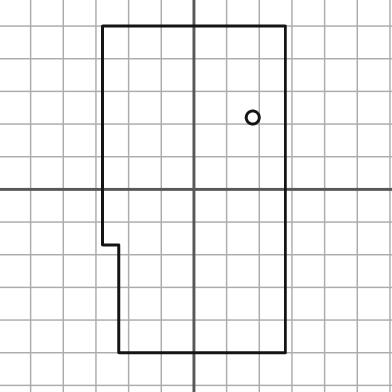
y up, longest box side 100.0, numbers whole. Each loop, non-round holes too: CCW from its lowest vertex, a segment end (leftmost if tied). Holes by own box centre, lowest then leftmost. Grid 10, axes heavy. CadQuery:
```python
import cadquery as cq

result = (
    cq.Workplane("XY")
    .moveTo(-23.0, -50.0)
    .lineTo(28.0, -50.0)
    .lineTo(28.0, 50.0)
    .lineTo(-28.0, 50.0)
    .lineTo(-28.0, -17.0)
    .lineTo(-23.0, -17.0)
    .close()
    .moveTo(18.0, 22.0)
    .circle(2.0)
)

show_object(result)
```